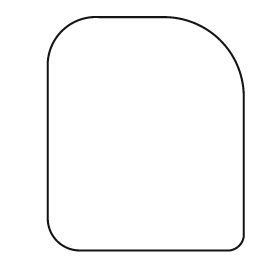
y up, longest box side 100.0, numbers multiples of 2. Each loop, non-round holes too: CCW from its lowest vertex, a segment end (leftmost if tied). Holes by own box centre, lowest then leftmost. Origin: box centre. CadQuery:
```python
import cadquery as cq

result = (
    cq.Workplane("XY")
    .moveTo(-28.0, -50.0)
    .lineTo(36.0, -50.0)
    .threePointArc((40.0, -48.0), (42.0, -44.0))
    .lineTo(42.0, 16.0)
    .threePointArc((32.0, 40.0), (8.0, 50.0))
    .lineTo(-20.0, 50.0)
    .threePointArc((-36.0, 44.0), (-42.0, 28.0))
    .lineTo(-42.0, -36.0)
    .threePointArc((-38.0, -46.0), (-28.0, -50.0))
    .close()
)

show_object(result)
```